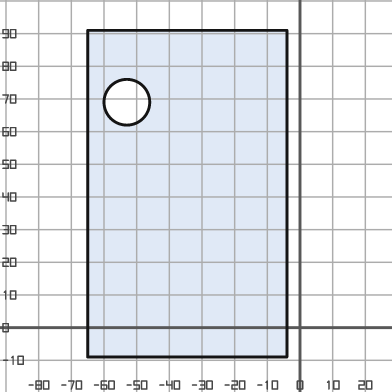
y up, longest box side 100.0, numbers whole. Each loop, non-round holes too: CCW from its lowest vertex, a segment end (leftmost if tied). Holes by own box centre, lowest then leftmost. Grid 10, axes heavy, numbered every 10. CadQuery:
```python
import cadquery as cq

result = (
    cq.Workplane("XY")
    .moveTo(-65.0, -9.0)
    .lineTo(-4.0, -9.0)
    .lineTo(-4.0, 91.0)
    .lineTo(-65.0, 91.0)
    .close()
    .moveTo(-53.0, 69.0)
    .circle(7.0)
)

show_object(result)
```